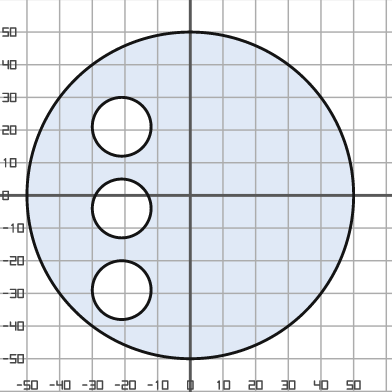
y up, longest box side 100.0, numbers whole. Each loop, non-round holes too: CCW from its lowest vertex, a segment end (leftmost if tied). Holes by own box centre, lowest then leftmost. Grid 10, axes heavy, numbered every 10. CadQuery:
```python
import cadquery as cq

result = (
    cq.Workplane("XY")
    .moveTo(0.0, 0.0)
    .circle(50.0)
    .moveTo(-21.0, -29.0)
    .circle(9.0)
    .moveTo(-21.0, -4.0)
    .circle(9.0)
    .moveTo(-21.0, 21.0)
    .circle(9.0)
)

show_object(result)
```